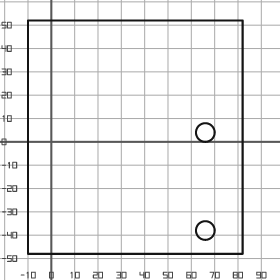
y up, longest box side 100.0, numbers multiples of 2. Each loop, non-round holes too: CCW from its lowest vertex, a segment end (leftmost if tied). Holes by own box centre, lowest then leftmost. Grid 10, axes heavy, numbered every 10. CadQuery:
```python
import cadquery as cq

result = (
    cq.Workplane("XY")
    .moveTo(-10.0, -48.0)
    .lineTo(82.0, -48.0)
    .lineTo(82.0, 52.0)
    .lineTo(-10.0, 52.0)
    .close()
    .moveTo(66.0, -38.0)
    .circle(4.0)
    .moveTo(66.0, 4.0)
    .circle(4.0)
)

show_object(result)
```